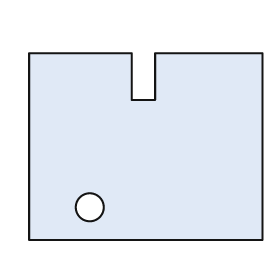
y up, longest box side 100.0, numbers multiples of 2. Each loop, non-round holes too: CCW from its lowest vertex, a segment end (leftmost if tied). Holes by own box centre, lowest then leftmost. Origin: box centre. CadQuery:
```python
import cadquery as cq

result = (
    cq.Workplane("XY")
    .moveTo(-50.0, -40.0)
    .lineTo(50.0, -40.0)
    .lineTo(50.0, 40.0)
    .lineTo(4.0, 40.0)
    .lineTo(4.0, 20.0)
    .lineTo(-6.0, 20.0)
    .lineTo(-6.0, 40.0)
    .lineTo(-50.0, 40.0)
    .close()
    .moveTo(-24.0, -26.0)
    .circle(6.0)
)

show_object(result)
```